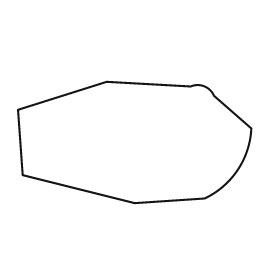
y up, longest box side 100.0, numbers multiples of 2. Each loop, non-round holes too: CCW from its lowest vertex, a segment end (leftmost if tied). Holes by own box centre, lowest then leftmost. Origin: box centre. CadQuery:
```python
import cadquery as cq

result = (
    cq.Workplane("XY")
    .moveTo(0.0, -26.0)
    .lineTo(30.0, -24.0)
    .threePointArc((44.0, -12.0), (50.0, 6.0))
    .lineTo(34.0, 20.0)
    .threePointArc((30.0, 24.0), (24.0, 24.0))
    .lineTo(-12.0, 26.0)
    .lineTo(-50.0, 14.0)
    .lineTo(-48.0, -14.0)
    .close()
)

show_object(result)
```